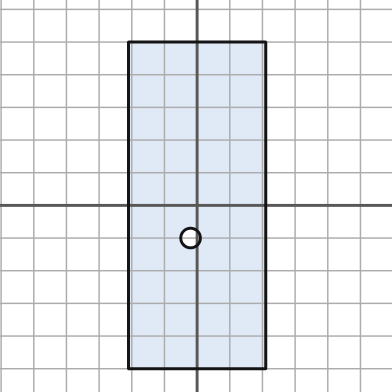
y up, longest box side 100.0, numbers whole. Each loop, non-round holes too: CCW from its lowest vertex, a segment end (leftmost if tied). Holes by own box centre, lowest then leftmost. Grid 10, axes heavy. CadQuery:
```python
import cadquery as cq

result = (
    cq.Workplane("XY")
    .moveTo(-21.0, -50.0)
    .lineTo(21.0, -50.0)
    .lineTo(21.0, 50.0)
    .lineTo(-21.0, 50.0)
    .close()
    .moveTo(-2.0, -10.0)
    .circle(3.0)
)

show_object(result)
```